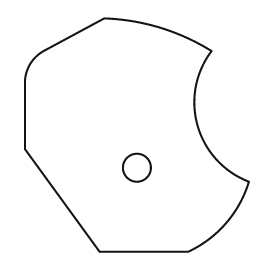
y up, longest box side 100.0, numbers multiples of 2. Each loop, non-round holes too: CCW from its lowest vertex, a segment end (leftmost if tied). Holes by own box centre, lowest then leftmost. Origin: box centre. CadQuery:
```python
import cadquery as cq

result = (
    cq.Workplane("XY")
    .moveTo(-16.0, -50.0)
    .lineTo(22.0, -50.0)
    .threePointArc((38.0, -38.0), (48.0, -20.0))
    .threePointArc((26.0, 4.0), (32.0, 36.0))
    .threePointArc((10.0, 46.0), (-14.0, 50.0))
    .lineTo(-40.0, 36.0)
    .threePointArc((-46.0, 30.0), (-48.0, 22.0))
    .lineTo(-48.0, -6.0)
    .close()
    .moveTo(0.0, -14.0)
    .circle(6.0)
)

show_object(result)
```